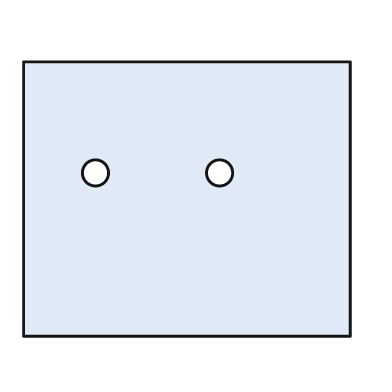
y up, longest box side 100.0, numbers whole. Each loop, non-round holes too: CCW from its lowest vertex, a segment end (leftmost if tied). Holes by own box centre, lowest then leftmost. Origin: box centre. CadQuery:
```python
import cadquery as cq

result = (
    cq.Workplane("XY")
    .moveTo(-50.0, -42.0)
    .lineTo(50.0, -42.0)
    .lineTo(50.0, 42.0)
    .lineTo(-50.0, 42.0)
    .close()
    .moveTo(-28.0, 8.0)
    .circle(4.0)
    .moveTo(10.0, 8.0)
    .circle(4.0)
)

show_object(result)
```